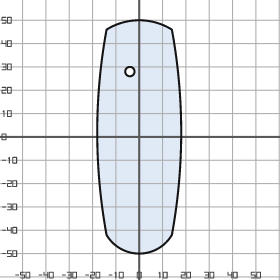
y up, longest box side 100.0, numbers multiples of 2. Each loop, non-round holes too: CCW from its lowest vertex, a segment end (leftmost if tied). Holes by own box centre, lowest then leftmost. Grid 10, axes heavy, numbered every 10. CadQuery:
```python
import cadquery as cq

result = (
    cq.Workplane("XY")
    .moveTo(-14.0, -42.0)
    .threePointArc((0.0, -50.0), (14.0, -42.0))
    .threePointArc((18.0, 2.0), (14.0, 46.0))
    .threePointArc((0.0, 50.0), (-14.0, 46.0))
    .threePointArc((-18.0, 2.0), (-14.0, -42.0))
    .close()
    .moveTo(-4.0, 28.0)
    .circle(2.0)
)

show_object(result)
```